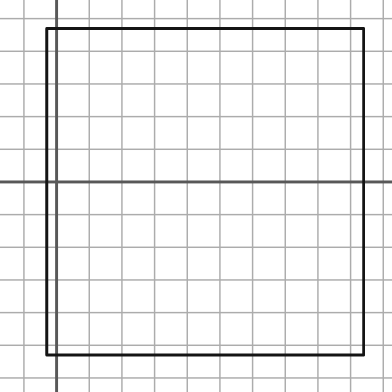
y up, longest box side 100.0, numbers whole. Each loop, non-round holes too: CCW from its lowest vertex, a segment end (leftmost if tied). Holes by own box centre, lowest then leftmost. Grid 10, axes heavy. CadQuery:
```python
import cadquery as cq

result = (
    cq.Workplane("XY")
    .moveTo(-3.0, -53.0)
    .lineTo(94.0, -53.0)
    .lineTo(94.0, 47.0)
    .lineTo(-3.0, 47.0)
    .close()
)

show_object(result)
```